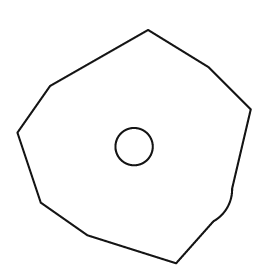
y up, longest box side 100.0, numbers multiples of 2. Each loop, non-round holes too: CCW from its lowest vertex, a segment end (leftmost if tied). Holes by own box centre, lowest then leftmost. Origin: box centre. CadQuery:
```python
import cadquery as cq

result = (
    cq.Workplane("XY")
    .moveTo(18.0, -50.0)
    .lineTo(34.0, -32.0)
    .threePointArc((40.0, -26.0), (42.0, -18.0))
    .lineTo(50.0, 16.0)
    .lineTo(32.0, 34.0)
    .lineTo(6.0, 50.0)
    .lineTo(-36.0, 26.0)
    .lineTo(-50.0, 6.0)
    .lineTo(-40.0, -24.0)
    .lineTo(-20.0, -38.0)
    .close()
    .moveTo(0.0, 0.0)
    .circle(8.0)
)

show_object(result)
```